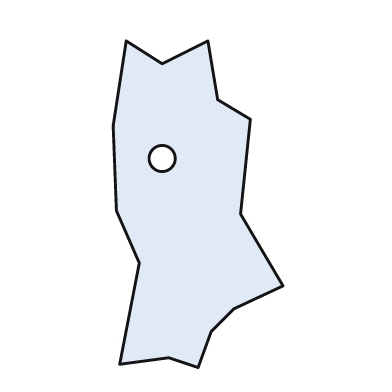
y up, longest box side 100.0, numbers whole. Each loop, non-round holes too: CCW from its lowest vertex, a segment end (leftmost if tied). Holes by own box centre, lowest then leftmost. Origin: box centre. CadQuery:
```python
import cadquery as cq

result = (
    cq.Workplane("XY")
    .moveTo(0.0, -50.0)
    .lineTo(4.0, -39.0)
    .lineTo(11.0, -32.0)
    .lineTo(26.0, -25.0)
    .lineTo(13.0, -3.0)
    .lineTo(16.0, 26.0)
    .lineTo(6.0, 32.0)
    .lineTo(3.0, 50.0)
    .lineTo(-11.0, 43.0)
    .lineTo(-22.0, 50.0)
    .lineTo(-26.0, 24.0)
    .lineTo(-25.0, -2.0)
    .lineTo(-18.0, -18.0)
    .lineTo(-24.0, -49.0)
    .lineTo(-9.0, -47.0)
    .close()
    .moveTo(-11.0, 14.0)
    .circle(4.0)
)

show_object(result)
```